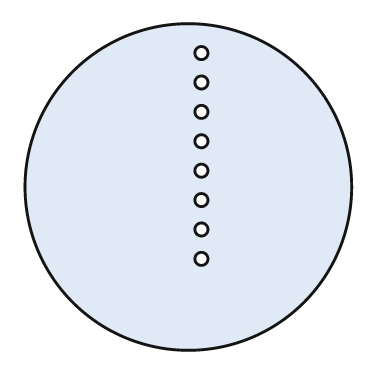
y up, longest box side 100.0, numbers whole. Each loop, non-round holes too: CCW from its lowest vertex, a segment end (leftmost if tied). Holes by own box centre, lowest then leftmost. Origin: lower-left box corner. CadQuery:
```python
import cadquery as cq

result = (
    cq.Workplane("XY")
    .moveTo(50.0, 50.0)
    .circle(50.0)
    .moveTo(54.0, 28.0)
    .circle(2.0)
    .moveTo(54.0, 37.0)
    .circle(2.0)
    .moveTo(54.0, 46.0)
    .circle(2.0)
    .moveTo(54.0, 55.0)
    .circle(2.0)
    .moveTo(54.0, 64.0)
    .circle(2.0)
    .moveTo(54.0, 73.0)
    .circle(2.0)
    .moveTo(54.0, 82.0)
    .circle(2.0)
    .moveTo(54.0, 91.0)
    .circle(2.0)
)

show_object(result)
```